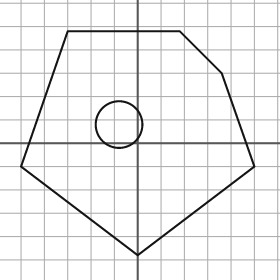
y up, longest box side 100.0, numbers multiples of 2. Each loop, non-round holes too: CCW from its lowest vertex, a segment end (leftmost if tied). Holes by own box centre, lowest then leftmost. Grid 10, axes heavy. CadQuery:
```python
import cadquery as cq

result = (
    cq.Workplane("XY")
    .moveTo(0.0, -48.0)
    .lineTo(50.0, -10.0)
    .lineTo(36.0, 30.0)
    .lineTo(18.0, 48.0)
    .lineTo(-30.0, 48.0)
    .lineTo(-50.0, -10.0)
    .close()
    .moveTo(-8.0, 8.0)
    .circle(10.0)
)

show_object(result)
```